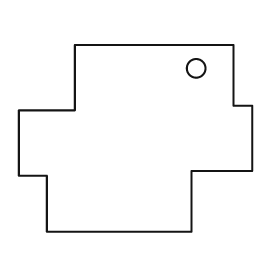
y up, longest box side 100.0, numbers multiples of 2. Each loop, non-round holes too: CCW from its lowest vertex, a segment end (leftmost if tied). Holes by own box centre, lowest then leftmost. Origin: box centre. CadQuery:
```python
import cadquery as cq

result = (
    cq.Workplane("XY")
    .moveTo(-38.0, -40.0)
    .lineTo(24.0, -40.0)
    .lineTo(24.0, -14.0)
    .lineTo(50.0, -14.0)
    .lineTo(50.0, 14.0)
    .lineTo(42.0, 14.0)
    .lineTo(42.0, 40.0)
    .lineTo(-26.0, 40.0)
    .lineTo(-26.0, 12.0)
    .lineTo(-50.0, 12.0)
    .lineTo(-50.0, -16.0)
    .lineTo(-38.0, -16.0)
    .close()
    .moveTo(26.0, 30.0)
    .circle(4.0)
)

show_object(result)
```